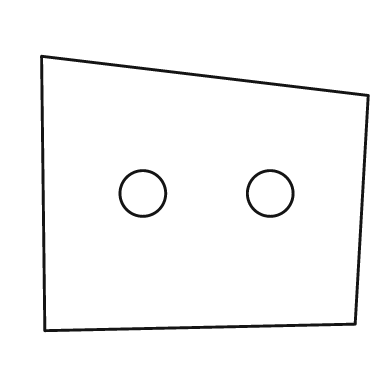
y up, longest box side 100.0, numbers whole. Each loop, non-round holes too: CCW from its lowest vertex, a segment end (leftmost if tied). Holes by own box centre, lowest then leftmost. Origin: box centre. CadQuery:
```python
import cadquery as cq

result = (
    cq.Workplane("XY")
    .moveTo(-49.0, -42.0)
    .lineTo(46.0, -40.0)
    .lineTo(50.0, 30.0)
    .lineTo(-50.0, 42.0)
    .close()
    .moveTo(-19.0, 0.0)
    .circle(7.0)
    .moveTo(20.0, 0.0)
    .circle(7.0)
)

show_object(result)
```